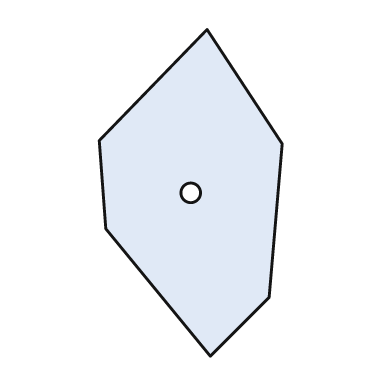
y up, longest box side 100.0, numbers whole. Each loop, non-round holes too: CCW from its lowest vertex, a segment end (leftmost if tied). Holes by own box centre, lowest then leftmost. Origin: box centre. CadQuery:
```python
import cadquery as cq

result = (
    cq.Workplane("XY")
    .moveTo(6.0, -50.0)
    .lineTo(24.0, -32.0)
    .lineTo(28.0, 15.0)
    .lineTo(5.0, 50.0)
    .lineTo(-28.0, 16.0)
    .lineTo(-26.0, -11.0)
    .close()
    .moveTo(0.0, 0.0)
    .circle(3.0)
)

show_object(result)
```